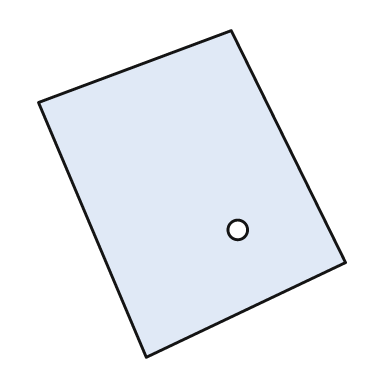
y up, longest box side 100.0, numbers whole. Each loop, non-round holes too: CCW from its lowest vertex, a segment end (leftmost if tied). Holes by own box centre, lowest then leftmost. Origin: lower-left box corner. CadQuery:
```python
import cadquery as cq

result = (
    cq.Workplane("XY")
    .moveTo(33.0, 0.0)
    .lineTo(94.0, 29.0)
    .lineTo(59.0, 100.0)
    .lineTo(0.0, 78.0)
    .close()
    .moveTo(61.0, 39.0)
    .circle(3.0)
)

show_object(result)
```